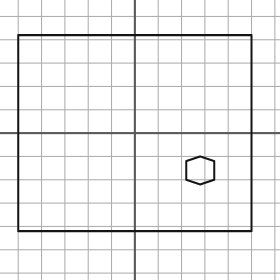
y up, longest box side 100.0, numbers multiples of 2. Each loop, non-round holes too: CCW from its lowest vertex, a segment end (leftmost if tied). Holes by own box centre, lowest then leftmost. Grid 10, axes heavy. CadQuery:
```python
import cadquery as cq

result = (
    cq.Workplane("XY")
    .moveTo(-50.0, -42.0)
    .lineTo(50.0, -42.0)
    .lineTo(50.0, 42.0)
    .lineTo(-50.0, 42.0)
    .close()
    .moveTo(28.0, -22.0)
    .lineTo(34.0, -20.0)
    .lineTo(34.0, -12.0)
    .lineTo(28.0, -10.0)
    .lineTo(22.0, -12.0)
    .lineTo(22.0, -20.0)
    .close()
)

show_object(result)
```